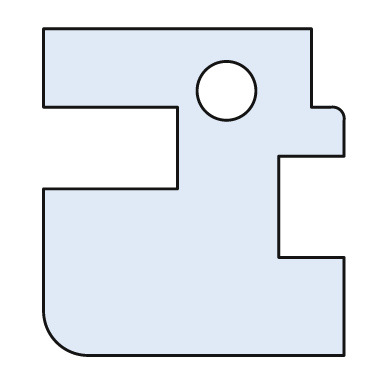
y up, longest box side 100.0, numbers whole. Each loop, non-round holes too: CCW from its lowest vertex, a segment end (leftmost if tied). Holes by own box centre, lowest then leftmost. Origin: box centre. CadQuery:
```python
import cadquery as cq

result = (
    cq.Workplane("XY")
    .moveTo(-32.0, -50.0)
    .lineTo(46.0, -50.0)
    .lineTo(46.0, -20.0)
    .lineTo(26.0, -20.0)
    .lineTo(26.0, 11.0)
    .lineTo(46.0, 11.0)
    .lineTo(46.0, 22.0)
    .threePointArc((45.0, 25.0), (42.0, 26.0))
    .lineTo(36.0, 26.0)
    .lineTo(36.0, 50.0)
    .lineTo(-46.0, 50.0)
    .lineTo(-46.0, 26.0)
    .lineTo(-5.0, 26.0)
    .lineTo(-5.0, 1.0)
    .lineTo(-46.0, 1.0)
    .lineTo(-46.0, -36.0)
    .threePointArc((-42.0, -46.0), (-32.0, -50.0))
    .close()
    .moveTo(10.0, 31.0)
    .circle(9.0)
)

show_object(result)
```